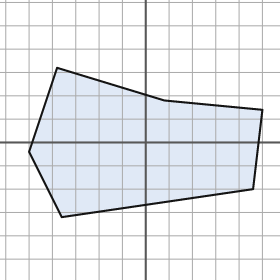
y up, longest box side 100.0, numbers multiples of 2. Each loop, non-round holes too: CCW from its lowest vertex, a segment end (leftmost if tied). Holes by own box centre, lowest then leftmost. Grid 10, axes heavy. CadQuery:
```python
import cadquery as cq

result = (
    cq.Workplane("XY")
    .moveTo(-36.0, -32.0)
    .lineTo(46.0, -20.0)
    .lineTo(50.0, 14.0)
    .lineTo(8.0, 18.0)
    .lineTo(-38.0, 32.0)
    .lineTo(-50.0, -4.0)
    .close()
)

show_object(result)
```